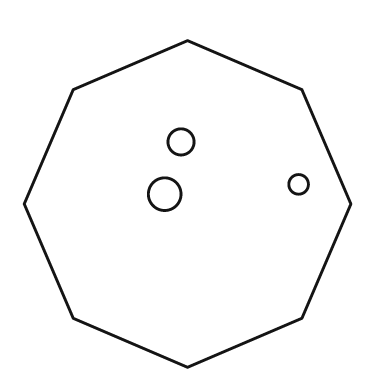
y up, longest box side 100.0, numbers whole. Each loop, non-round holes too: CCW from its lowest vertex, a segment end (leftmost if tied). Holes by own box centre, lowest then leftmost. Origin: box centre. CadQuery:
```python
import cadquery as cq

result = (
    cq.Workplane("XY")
    .moveTo(0.0, -50.0)
    .lineTo(35.0, -35.0)
    .lineTo(50.0, 0.0)
    .lineTo(35.0, 35.0)
    .lineTo(0.0, 50.0)
    .lineTo(-35.0, 35.0)
    .lineTo(-50.0, 0.0)
    .lineTo(-35.0, -35.0)
    .close()
    .moveTo(-7.0, 3.0)
    .circle(5.0)
    .moveTo(34.0, 6.0)
    .circle(3.0)
    .moveTo(-2.0, 19.0)
    .circle(4.0)
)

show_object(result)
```